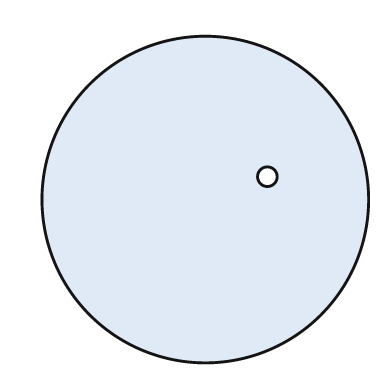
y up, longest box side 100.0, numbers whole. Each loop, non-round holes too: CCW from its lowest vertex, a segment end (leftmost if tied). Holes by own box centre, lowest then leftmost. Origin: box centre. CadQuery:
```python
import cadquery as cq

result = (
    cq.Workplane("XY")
    .moveTo(0.0, 0.0)
    .circle(50.0)
    .moveTo(19.0, 7.0)
    .circle(3.0)
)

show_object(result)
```